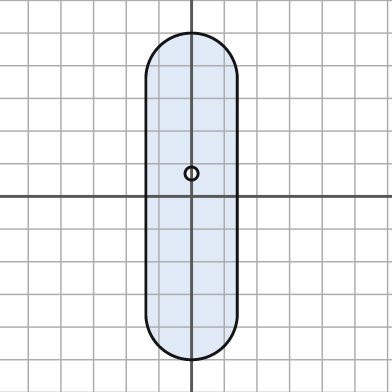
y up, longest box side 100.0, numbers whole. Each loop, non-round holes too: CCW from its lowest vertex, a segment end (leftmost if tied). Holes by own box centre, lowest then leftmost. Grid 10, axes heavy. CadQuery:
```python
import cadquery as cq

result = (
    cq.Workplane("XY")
    .moveTo(-14.0, -36.0)
    .threePointArc((0.0, -50.0), (14.0, -36.0))
    .lineTo(14.0, 36.0)
    .threePointArc((0.0, 50.0), (-14.0, 36.0))
    .close()
    .moveTo(0.0, 7.0)
    .circle(2.0)
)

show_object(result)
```